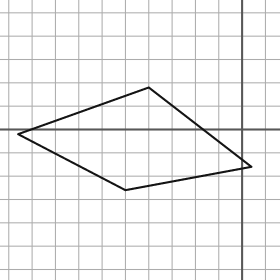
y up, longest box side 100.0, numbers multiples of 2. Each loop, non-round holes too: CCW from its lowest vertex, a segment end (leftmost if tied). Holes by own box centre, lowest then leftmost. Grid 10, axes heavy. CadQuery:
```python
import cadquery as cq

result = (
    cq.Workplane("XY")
    .moveTo(-50.0, -26.0)
    .lineTo(4.0, -16.0)
    .lineTo(-40.0, 18.0)
    .lineTo(-96.0, -2.0)
    .close()
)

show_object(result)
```